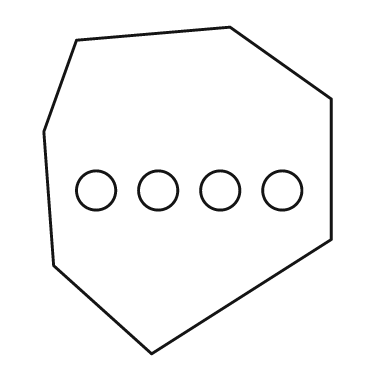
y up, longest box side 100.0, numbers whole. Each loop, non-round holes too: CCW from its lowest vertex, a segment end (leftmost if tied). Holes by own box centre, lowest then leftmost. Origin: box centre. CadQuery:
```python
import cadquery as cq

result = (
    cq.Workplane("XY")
    .moveTo(-11.0, -50.0)
    .lineTo(44.0, -15.0)
    .lineTo(44.0, 28.0)
    .lineTo(13.0, 50.0)
    .lineTo(-34.0, 46.0)
    .lineTo(-44.0, 18.0)
    .lineTo(-41.0, -23.0)
    .close()
    .moveTo(-28.0, 0.0)
    .circle(6.0)
    .moveTo(-9.0, 0.0)
    .circle(6.0)
    .moveTo(10.0, 0.0)
    .circle(6.0)
    .moveTo(29.0, 0.0)
    .circle(6.0)
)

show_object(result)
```